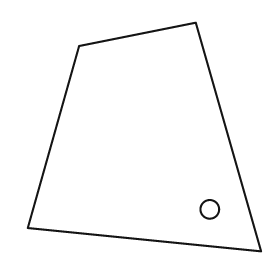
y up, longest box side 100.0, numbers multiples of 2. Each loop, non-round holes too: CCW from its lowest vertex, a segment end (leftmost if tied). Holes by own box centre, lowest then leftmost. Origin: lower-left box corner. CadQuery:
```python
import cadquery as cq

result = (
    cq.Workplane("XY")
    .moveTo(100.0, 0.0)
    .lineTo(72.0, 98.0)
    .lineTo(22.0, 88.0)
    .lineTo(0.0, 10.0)
    .close()
    .moveTo(78.0, 18.0)
    .circle(4.0)
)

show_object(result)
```